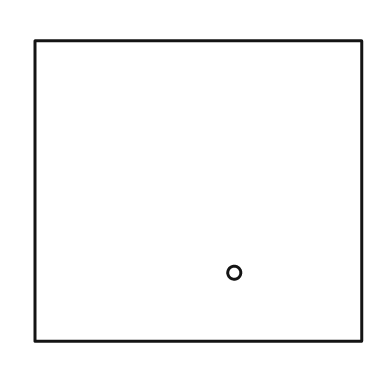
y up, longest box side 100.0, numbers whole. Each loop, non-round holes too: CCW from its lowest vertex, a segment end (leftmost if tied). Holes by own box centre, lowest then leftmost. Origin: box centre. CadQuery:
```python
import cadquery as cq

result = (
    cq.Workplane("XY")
    .moveTo(-50.0, -46.0)
    .lineTo(50.0, -46.0)
    .lineTo(50.0, 46.0)
    .lineTo(-50.0, 46.0)
    .close()
    .moveTo(11.0, -25.0)
    .circle(2.0)
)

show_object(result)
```